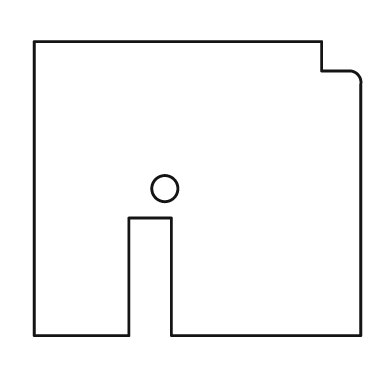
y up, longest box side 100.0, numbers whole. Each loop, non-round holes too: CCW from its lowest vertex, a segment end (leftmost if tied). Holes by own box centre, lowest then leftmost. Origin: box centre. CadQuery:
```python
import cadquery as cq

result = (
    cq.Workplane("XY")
    .moveTo(-50.0, -45.0)
    .lineTo(-21.0, -45.0)
    .lineTo(-21.0, -9.0)
    .lineTo(-8.0, -9.0)
    .lineTo(-8.0, -45.0)
    .lineTo(50.0, -45.0)
    .lineTo(50.0, 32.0)
    .threePointArc((49.0, 35.0), (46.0, 36.0))
    .lineTo(38.0, 36.0)
    .lineTo(38.0, 45.0)
    .lineTo(-50.0, 45.0)
    .close()
    .moveTo(-10.0, 0.0)
    .circle(4.0)
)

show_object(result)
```